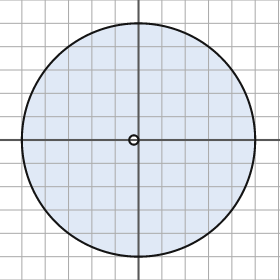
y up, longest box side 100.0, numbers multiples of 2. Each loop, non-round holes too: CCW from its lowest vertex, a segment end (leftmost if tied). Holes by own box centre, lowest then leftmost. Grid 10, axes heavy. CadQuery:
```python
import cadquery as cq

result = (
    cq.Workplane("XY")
    .moveTo(0.0, 0.0)
    .circle(50.0)
    .moveTo(-2.0, 0.0)
    .circle(2.0)
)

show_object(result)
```